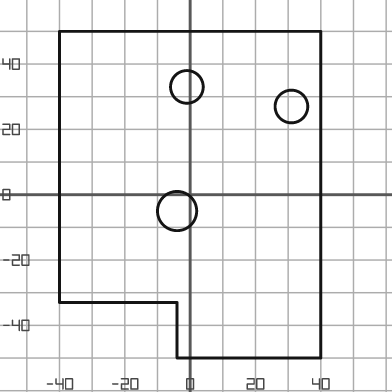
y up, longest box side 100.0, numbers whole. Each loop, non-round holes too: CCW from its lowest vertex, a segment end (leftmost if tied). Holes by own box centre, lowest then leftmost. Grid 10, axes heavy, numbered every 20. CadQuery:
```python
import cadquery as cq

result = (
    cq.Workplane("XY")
    .moveTo(-4.0, -50.0)
    .lineTo(40.0, -50.0)
    .lineTo(40.0, 50.0)
    .lineTo(-40.0, 50.0)
    .lineTo(-40.0, -33.0)
    .lineTo(-4.0, -33.0)
    .close()
    .moveTo(-4.0, -5.0)
    .circle(6.0)
    .moveTo(31.0, 27.0)
    .circle(5.0)
    .moveTo(-1.0, 33.0)
    .circle(5.0)
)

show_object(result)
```